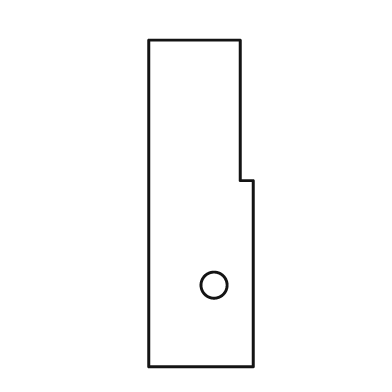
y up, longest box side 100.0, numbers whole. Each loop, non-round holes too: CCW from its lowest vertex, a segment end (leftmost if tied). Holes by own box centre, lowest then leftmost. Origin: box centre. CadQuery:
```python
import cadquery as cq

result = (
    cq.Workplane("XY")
    .moveTo(-16.0, -50.0)
    .lineTo(16.0, -50.0)
    .lineTo(16.0, 7.0)
    .lineTo(12.0, 7.0)
    .lineTo(12.0, 50.0)
    .lineTo(-16.0, 50.0)
    .close()
    .moveTo(4.0, -25.0)
    .circle(4.0)
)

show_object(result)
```